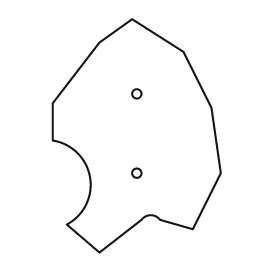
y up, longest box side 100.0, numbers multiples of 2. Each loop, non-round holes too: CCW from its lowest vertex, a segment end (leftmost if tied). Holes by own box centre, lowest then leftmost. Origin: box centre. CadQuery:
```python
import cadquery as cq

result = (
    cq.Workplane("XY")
    .moveTo(-16.0, -50.0)
    .lineTo(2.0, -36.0)
    .threePointArc((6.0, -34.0), (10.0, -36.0))
    .lineTo(24.0, -40.0)
    .lineTo(36.0, -16.0)
    .lineTo(32.0, 12.0)
    .lineTo(20.0, 36.0)
    .lineTo(-2.0, 50.0)
    .lineTo(-16.0, 40.0)
    .lineTo(-36.0, 14.0)
    .lineTo(-36.0, -2.0)
    .threePointArc((-20.0, -18.0), (-30.0, -38.0))
    .close()
    .moveTo(0.0, -16.0)
    .circle(2.0)
    .moveTo(0.0, 18.0)
    .circle(2.0)
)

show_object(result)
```